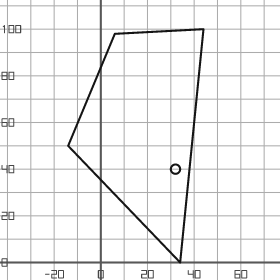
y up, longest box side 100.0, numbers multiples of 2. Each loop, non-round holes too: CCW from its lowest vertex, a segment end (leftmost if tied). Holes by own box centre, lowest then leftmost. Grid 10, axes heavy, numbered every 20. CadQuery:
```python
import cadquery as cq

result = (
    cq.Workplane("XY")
    .moveTo(34.0, 0.0)
    .lineTo(44.0, 100.0)
    .lineTo(6.0, 98.0)
    .lineTo(-14.0, 50.0)
    .close()
    .moveTo(32.0, 40.0)
    .circle(2.0)
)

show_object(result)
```